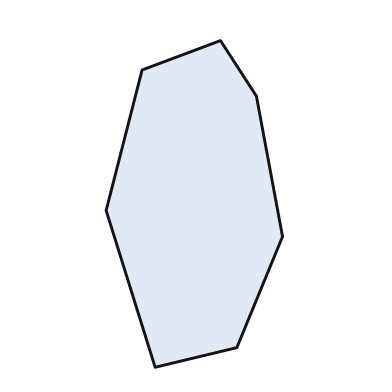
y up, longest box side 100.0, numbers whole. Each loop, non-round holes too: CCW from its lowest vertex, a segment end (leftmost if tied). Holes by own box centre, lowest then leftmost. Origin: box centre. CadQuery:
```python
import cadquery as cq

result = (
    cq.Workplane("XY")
    .moveTo(-12.0, -50.0)
    .lineTo(13.0, -44.0)
    .lineTo(27.0, -10.0)
    .lineTo(19.0, 33.0)
    .lineTo(8.0, 50.0)
    .lineTo(-16.0, 41.0)
    .lineTo(-27.0, -2.0)
    .close()
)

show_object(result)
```